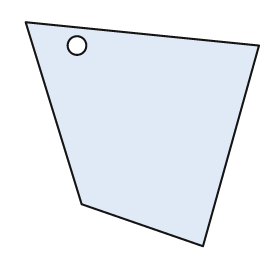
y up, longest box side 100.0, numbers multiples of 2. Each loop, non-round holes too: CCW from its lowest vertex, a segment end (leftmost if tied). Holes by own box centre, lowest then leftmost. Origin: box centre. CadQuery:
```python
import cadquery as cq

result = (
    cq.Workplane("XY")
    .moveTo(26.0, -48.0)
    .lineTo(50.0, 38.0)
    .lineTo(-50.0, 48.0)
    .lineTo(-26.0, -30.0)
    .close()
    .moveTo(-28.0, 38.0)
    .circle(4.0)
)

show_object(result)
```